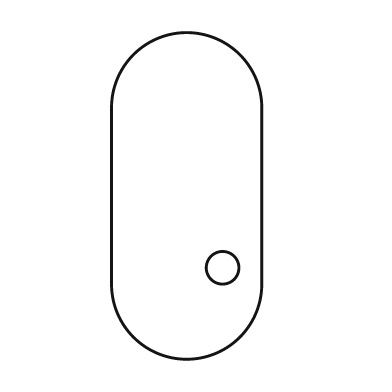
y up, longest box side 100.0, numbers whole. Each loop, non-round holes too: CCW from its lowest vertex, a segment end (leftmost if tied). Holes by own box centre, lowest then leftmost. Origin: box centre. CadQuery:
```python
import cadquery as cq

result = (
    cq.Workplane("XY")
    .moveTo(-23.0, -27.0)
    .threePointArc((0.0, -50.0), (23.0, -27.0))
    .lineTo(23.0, 27.0)
    .threePointArc((0.0, 50.0), (-23.0, 27.0))
    .close()
    .moveTo(11.0, -22.0)
    .circle(5.0)
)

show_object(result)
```